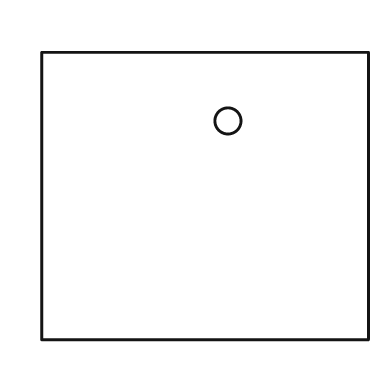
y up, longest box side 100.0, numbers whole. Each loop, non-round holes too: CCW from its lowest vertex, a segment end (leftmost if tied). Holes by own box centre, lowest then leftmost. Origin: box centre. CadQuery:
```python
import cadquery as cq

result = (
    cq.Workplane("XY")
    .moveTo(-50.0, -44.0)
    .lineTo(50.0, -44.0)
    .lineTo(50.0, 44.0)
    .lineTo(-50.0, 44.0)
    .close()
    .moveTo(7.0, 23.0)
    .circle(4.0)
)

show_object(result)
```